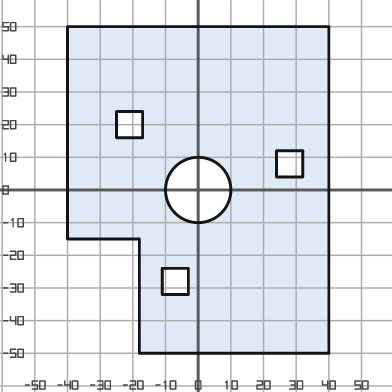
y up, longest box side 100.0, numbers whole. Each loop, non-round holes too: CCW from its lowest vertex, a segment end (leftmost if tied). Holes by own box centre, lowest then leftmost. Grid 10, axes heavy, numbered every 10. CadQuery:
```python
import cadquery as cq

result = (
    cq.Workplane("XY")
    .moveTo(-18.0, -50.0)
    .lineTo(40.0, -50.0)
    .lineTo(40.0, 50.0)
    .lineTo(-40.0, 50.0)
    .lineTo(-40.0, -15.0)
    .lineTo(-18.0, -15.0)
    .close()
    .moveTo(-11.0, -32.0)
    .lineTo(-3.0, -32.0)
    .lineTo(-3.0, -24.0)
    .lineTo(-11.0, -24.0)
    .close()
    .moveTo(0.0, 0.0)
    .circle(10.0)
    .moveTo(24.0, 4.0)
    .lineTo(32.0, 4.0)
    .lineTo(32.0, 12.0)
    .lineTo(24.0, 12.0)
    .close()
    .moveTo(-25.0, 16.0)
    .lineTo(-17.0, 16.0)
    .lineTo(-17.0, 24.0)
    .lineTo(-25.0, 24.0)
    .close()
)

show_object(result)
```